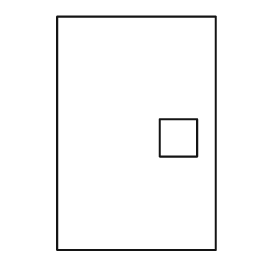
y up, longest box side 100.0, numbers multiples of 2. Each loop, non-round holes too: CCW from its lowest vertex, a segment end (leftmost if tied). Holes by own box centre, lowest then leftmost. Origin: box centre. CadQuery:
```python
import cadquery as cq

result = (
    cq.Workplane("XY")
    .moveTo(-34.0, -50.0)
    .lineTo(34.0, -50.0)
    .lineTo(34.0, 50.0)
    .lineTo(-34.0, 50.0)
    .close()
    .moveTo(10.0, -10.0)
    .lineTo(26.0, -10.0)
    .lineTo(26.0, 6.0)
    .lineTo(10.0, 6.0)
    .close()
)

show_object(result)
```